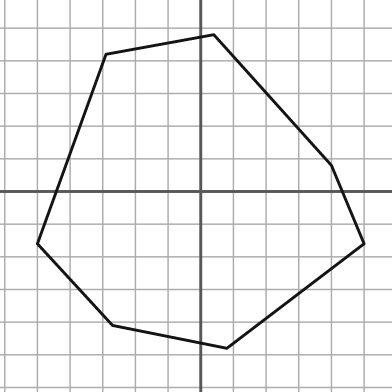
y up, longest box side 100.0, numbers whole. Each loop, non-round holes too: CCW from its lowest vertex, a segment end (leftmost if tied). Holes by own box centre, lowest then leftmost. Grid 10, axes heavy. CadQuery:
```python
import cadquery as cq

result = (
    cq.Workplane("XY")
    .moveTo(8.0, -48.0)
    .lineTo(50.0, -16.0)
    .lineTo(40.0, 8.0)
    .lineTo(4.0, 48.0)
    .lineTo(-29.0, 42.0)
    .lineTo(-50.0, -16.0)
    .lineTo(-27.0, -41.0)
    .close()
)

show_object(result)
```